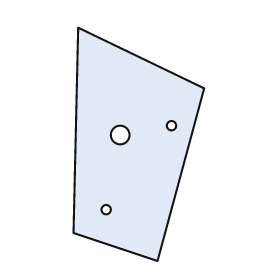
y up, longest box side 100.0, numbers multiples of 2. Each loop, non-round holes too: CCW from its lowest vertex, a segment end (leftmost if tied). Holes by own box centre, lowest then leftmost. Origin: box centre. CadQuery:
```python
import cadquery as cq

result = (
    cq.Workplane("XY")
    .moveTo(8.0, -50.0)
    .lineTo(28.0, 24.0)
    .lineTo(-26.0, 50.0)
    .lineTo(-28.0, -38.0)
    .close()
    .moveTo(-14.0, -28.0)
    .circle(2.0)
    .moveTo(-8.0, 4.0)
    .circle(4.0)
    .moveTo(14.0, 8.0)
    .circle(2.0)
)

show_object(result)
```